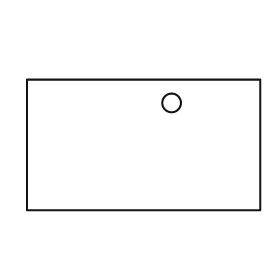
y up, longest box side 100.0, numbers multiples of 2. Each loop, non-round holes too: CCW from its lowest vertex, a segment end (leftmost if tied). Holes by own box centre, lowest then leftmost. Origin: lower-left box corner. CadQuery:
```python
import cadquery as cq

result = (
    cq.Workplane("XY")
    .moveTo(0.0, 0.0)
    .lineTo(100.0, 0.0)
    .lineTo(100.0, 56.0)
    .lineTo(0.0, 56.0)
    .close()
    .moveTo(62.0, 46.0)
    .circle(4.0)
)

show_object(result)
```